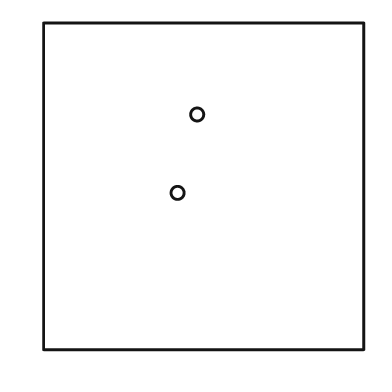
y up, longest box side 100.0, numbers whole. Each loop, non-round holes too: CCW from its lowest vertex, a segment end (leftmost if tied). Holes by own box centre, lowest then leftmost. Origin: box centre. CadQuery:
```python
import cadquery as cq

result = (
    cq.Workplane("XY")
    .moveTo(-49.0, -50.0)
    .lineTo(49.0, -50.0)
    .lineTo(49.0, 50.0)
    .lineTo(-49.0, 50.0)
    .close()
    .moveTo(-8.0, -2.0)
    .circle(2.0)
    .moveTo(-2.0, 22.0)
    .circle(2.0)
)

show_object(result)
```